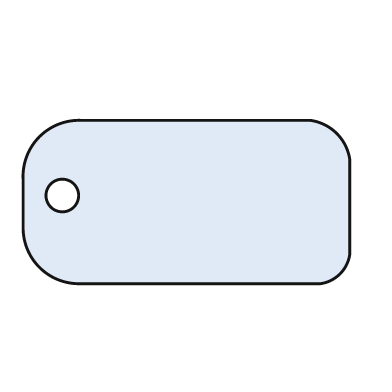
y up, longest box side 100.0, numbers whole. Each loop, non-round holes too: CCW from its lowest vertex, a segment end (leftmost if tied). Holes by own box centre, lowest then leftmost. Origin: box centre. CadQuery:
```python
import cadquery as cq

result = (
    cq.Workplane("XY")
    .moveTo(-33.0, -25.0)
    .lineTo(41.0, -25.0)
    .threePointArc((47.0, -22.0), (50.0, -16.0))
    .lineTo(50.0, 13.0)
    .threePointArc((46.0, 21.0), (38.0, 25.0))
    .lineTo(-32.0, 25.0)
    .threePointArc((-45.0, 20.0), (-50.0, 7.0))
    .lineTo(-50.0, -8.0)
    .threePointArc((-45.0, -20.0), (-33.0, -25.0))
    .close()
    .moveTo(-38.0, 2.0)
    .circle(5.0)
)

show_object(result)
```